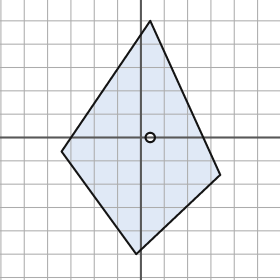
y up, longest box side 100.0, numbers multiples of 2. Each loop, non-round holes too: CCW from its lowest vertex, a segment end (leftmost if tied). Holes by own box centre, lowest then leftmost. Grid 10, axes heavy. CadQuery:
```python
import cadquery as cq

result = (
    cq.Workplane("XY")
    .moveTo(-2.0, -50.0)
    .lineTo(34.0, -16.0)
    .lineTo(4.0, 50.0)
    .lineTo(-34.0, -6.0)
    .close()
    .moveTo(4.0, 0.0)
    .circle(2.0)
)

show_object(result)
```